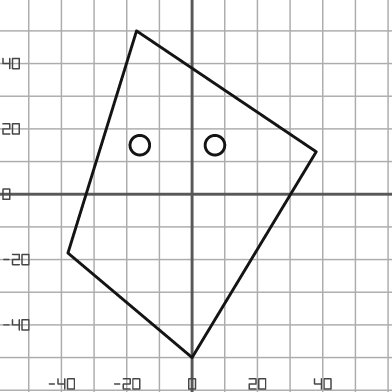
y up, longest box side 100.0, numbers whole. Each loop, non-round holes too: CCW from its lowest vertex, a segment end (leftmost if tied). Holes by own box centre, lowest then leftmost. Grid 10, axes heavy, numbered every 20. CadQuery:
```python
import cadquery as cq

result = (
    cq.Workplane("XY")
    .moveTo(0.0, -50.0)
    .lineTo(38.0, 13.0)
    .lineTo(-17.0, 50.0)
    .lineTo(-38.0, -18.0)
    .close()
    .moveTo(-16.0, 15.0)
    .circle(3.0)
    .moveTo(7.0, 15.0)
    .circle(3.0)
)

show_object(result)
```